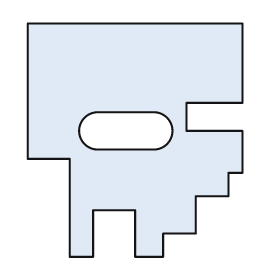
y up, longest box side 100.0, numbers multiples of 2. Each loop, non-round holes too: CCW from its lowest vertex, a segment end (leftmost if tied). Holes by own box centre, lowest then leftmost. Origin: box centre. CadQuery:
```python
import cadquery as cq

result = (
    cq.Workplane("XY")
    .moveTo(-28.0, -50.0)
    .lineTo(-18.0, -50.0)
    .lineTo(-18.0, -30.0)
    .lineTo(0.0, -30.0)
    .lineTo(0.0, -50.0)
    .lineTo(12.0, -50.0)
    .lineTo(12.0, -40.0)
    .lineTo(26.0, -40.0)
    .lineTo(26.0, -24.0)
    .lineTo(40.0, -24.0)
    .lineTo(40.0, -14.0)
    .lineTo(46.0, -14.0)
    .lineTo(46.0, 4.0)
    .lineTo(22.0, 4.0)
    .lineTo(22.0, 16.0)
    .lineTo(46.0, 16.0)
    .lineTo(46.0, 50.0)
    .lineTo(-46.0, 50.0)
    .lineTo(-46.0, -8.0)
    .lineTo(-28.0, -8.0)
    .close()
    .moveTo(-16.0, -4.0)
    .lineTo(8.0, -4.0)
    .threePointArc((16.0, 4.0), (8.0, 12.0))
    .lineTo(-16.0, 12.0)
    .threePointArc((-24.0, 4.0), (-16.0, -4.0))
    .close()
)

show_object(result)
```